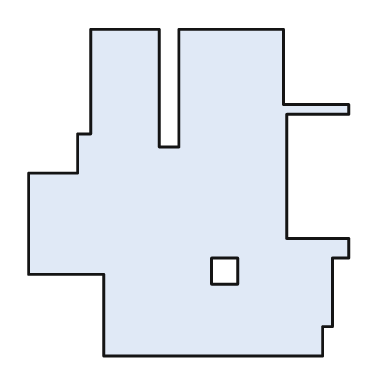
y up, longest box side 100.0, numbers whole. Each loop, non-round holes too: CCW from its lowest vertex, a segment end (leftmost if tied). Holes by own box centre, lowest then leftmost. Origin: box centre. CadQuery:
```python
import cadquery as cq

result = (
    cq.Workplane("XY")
    .moveTo(-26.0, -50.0)
    .lineTo(41.0, -50.0)
    .lineTo(41.0, -41.0)
    .lineTo(44.0, -41.0)
    .lineTo(44.0, -20.0)
    .lineTo(49.0, -20.0)
    .lineTo(49.0, -14.0)
    .lineTo(30.0, -14.0)
    .lineTo(30.0, 24.0)
    .lineTo(49.0, 24.0)
    .lineTo(49.0, 27.0)
    .lineTo(29.0, 27.0)
    .lineTo(29.0, 50.0)
    .lineTo(-3.0, 50.0)
    .lineTo(-3.0, 14.0)
    .lineTo(-9.0, 14.0)
    .lineTo(-9.0, 50.0)
    .lineTo(-30.0, 50.0)
    .lineTo(-30.0, 18.0)
    .lineTo(-34.0, 18.0)
    .lineTo(-34.0, 6.0)
    .lineTo(-49.0, 6.0)
    .lineTo(-49.0, -25.0)
    .lineTo(-26.0, -25.0)
    .close()
    .moveTo(7.0, -28.0)
    .lineTo(15.0, -28.0)
    .lineTo(15.0, -20.0)
    .lineTo(7.0, -20.0)
    .close()
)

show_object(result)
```